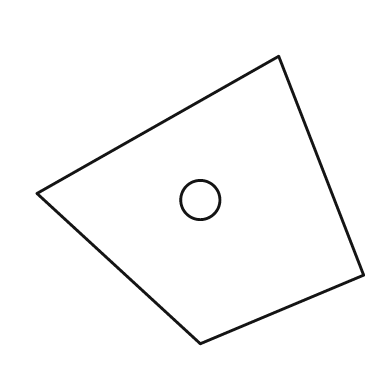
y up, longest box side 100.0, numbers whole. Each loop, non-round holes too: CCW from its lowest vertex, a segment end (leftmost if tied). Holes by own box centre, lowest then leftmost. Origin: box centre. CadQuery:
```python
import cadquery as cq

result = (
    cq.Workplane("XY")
    .moveTo(0.0, -44.0)
    .lineTo(50.0, -23.0)
    .lineTo(24.0, 44.0)
    .lineTo(-50.0, 2.0)
    .close()
    .moveTo(0.0, 0.0)
    .circle(6.0)
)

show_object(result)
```